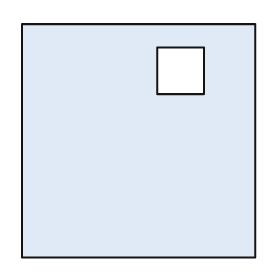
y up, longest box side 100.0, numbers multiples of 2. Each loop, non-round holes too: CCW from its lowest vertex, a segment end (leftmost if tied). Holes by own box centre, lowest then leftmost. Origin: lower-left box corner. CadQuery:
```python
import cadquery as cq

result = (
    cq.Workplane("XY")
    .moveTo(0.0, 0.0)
    .lineTo(100.0, 0.0)
    .lineTo(100.0, 100.0)
    .lineTo(0.0, 100.0)
    .close()
    .moveTo(58.0, 70.0)
    .lineTo(78.0, 70.0)
    .lineTo(78.0, 90.0)
    .lineTo(58.0, 90.0)
    .close()
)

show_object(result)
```